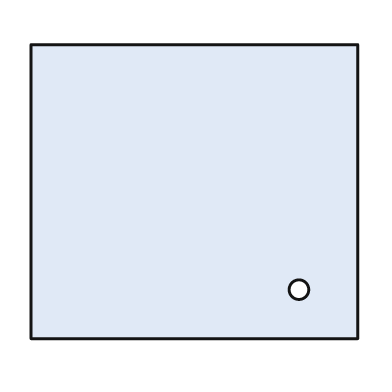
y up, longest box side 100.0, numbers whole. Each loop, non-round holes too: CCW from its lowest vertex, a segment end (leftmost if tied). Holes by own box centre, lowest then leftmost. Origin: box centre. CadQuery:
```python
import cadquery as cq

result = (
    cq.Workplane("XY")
    .moveTo(-50.0, -45.0)
    .lineTo(50.0, -45.0)
    .lineTo(50.0, 45.0)
    .lineTo(-50.0, 45.0)
    .close()
    .moveTo(32.0, -30.0)
    .circle(3.0)
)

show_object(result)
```